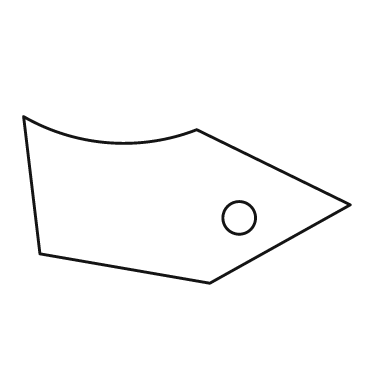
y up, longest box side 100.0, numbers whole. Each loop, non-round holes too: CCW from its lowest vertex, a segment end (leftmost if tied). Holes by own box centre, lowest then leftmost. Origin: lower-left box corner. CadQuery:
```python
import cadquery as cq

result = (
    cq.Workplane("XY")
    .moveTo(57.0, 0.0)
    .lineTo(100.0, 24.0)
    .lineTo(53.0, 47.0)
    .threePointArc((26.0, 43.0), (0.0, 51.0))
    .lineTo(5.0, 9.0)
    .close()
    .moveTo(66.0, 20.0)
    .circle(5.0)
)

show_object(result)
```